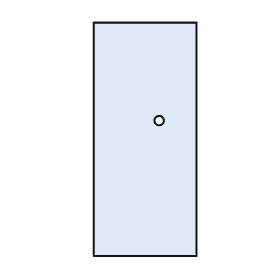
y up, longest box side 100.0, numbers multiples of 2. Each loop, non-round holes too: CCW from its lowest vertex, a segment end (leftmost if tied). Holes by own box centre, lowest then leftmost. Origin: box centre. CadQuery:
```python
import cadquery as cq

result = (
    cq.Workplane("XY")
    .moveTo(-22.0, -50.0)
    .lineTo(22.0, -50.0)
    .lineTo(22.0, 50.0)
    .lineTo(-22.0, 50.0)
    .close()
    .moveTo(6.0, 8.0)
    .circle(2.0)
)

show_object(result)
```